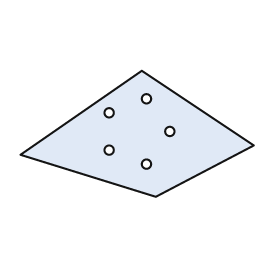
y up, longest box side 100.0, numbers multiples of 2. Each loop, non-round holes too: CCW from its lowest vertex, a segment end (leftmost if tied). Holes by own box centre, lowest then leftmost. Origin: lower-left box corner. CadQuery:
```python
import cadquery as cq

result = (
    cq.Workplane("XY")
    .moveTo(58.0, 0.0)
    .lineTo(100.0, 22.0)
    .lineTo(52.0, 54.0)
    .lineTo(0.0, 18.0)
    .close()
    .moveTo(54.0, 14.0)
    .circle(2.0)
    .moveTo(38.0, 20.0)
    .circle(2.0)
    .moveTo(64.0, 28.0)
    .circle(2.0)
    .moveTo(38.0, 36.0)
    .circle(2.0)
    .moveTo(54.0, 42.0)
    .circle(2.0)
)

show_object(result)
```